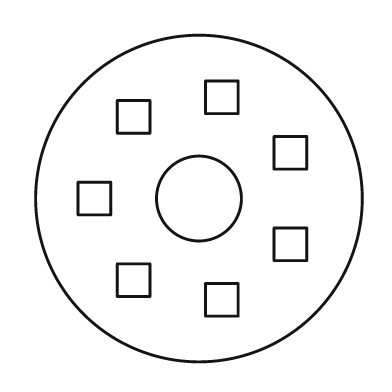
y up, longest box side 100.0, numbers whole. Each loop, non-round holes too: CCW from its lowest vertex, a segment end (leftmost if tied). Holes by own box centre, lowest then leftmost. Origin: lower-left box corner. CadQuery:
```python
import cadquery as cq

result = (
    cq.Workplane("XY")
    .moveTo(50.0, 50.0)
    .circle(50.0)
    .moveTo(52.0, 14.0)
    .lineTo(62.0, 14.0)
    .lineTo(62.0, 24.0)
    .lineTo(52.0, 24.0)
    .close()
    .moveTo(25.0, 20.0)
    .lineTo(35.0, 20.0)
    .lineTo(35.0, 30.0)
    .lineTo(25.0, 30.0)
    .close()
    .moveTo(73.0, 31.0)
    .lineTo(83.0, 31.0)
    .lineTo(83.0, 41.0)
    .lineTo(73.0, 41.0)
    .close()
    .moveTo(13.0, 45.0)
    .lineTo(23.0, 45.0)
    .lineTo(23.0, 55.0)
    .lineTo(13.0, 55.0)
    .close()
    .moveTo(50.0, 50.0)
    .circle(13.0)
    .moveTo(73.0, 59.0)
    .lineTo(83.0, 59.0)
    .lineTo(83.0, 69.0)
    .lineTo(73.0, 69.0)
    .close()
    .moveTo(25.0, 70.0)
    .lineTo(35.0, 70.0)
    .lineTo(35.0, 80.0)
    .lineTo(25.0, 80.0)
    .close()
    .moveTo(52.0, 76.0)
    .lineTo(62.0, 76.0)
    .lineTo(62.0, 86.0)
    .lineTo(52.0, 86.0)
    .close()
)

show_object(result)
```